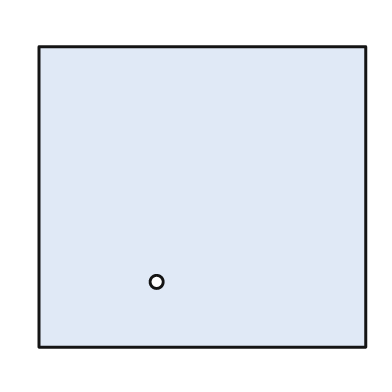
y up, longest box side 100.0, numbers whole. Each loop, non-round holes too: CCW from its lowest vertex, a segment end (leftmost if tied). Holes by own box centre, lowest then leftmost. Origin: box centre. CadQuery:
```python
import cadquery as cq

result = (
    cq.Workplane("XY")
    .moveTo(-50.0, -46.0)
    .lineTo(50.0, -46.0)
    .lineTo(50.0, 46.0)
    .lineTo(-50.0, 46.0)
    .close()
    .moveTo(-14.0, -26.0)
    .circle(2.0)
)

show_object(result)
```